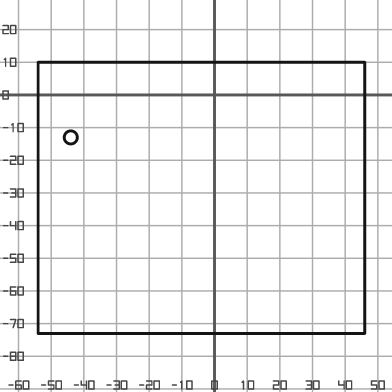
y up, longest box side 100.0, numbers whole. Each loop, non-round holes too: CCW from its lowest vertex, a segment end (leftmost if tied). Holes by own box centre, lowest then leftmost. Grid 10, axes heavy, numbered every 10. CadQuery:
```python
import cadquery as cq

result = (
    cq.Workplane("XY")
    .moveTo(-54.0, -73.0)
    .lineTo(46.0, -73.0)
    .lineTo(46.0, 10.0)
    .lineTo(-54.0, 10.0)
    .close()
    .moveTo(-44.0, -13.0)
    .circle(2.0)
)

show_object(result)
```